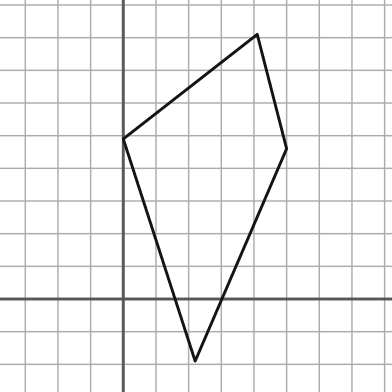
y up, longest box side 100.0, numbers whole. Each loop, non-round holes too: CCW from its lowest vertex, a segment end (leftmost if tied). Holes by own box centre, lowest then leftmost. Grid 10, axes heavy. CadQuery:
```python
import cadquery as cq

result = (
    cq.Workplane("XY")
    .moveTo(22.0, -19.0)
    .lineTo(50.0, 46.0)
    .lineTo(41.0, 81.0)
    .lineTo(0.0, 49.0)
    .close()
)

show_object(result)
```